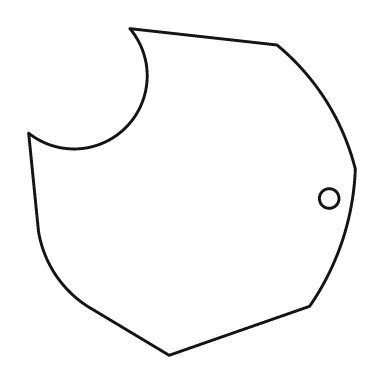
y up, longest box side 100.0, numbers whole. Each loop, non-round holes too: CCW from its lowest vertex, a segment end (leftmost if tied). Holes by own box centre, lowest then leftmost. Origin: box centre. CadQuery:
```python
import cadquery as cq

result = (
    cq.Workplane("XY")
    .moveTo(-7.0, -50.0)
    .lineTo(36.0, -35.0)
    .threePointArc((46.0, -15.0), (50.0, 7.0))
    .threePointArc((41.0, 28.0), (26.0, 45.0))
    .lineTo(-19.0, 50.0)
    .threePointArc((-20.0, 20.0), (-50.0, 18.0))
    .lineTo(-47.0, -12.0)
    .threePointArc((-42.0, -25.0), (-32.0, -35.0))
    .close()
    .moveTo(42.0, -2.0)
    .circle(3.0)
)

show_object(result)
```